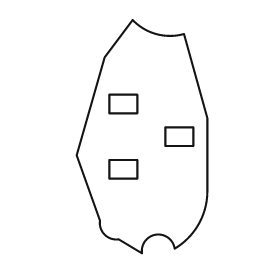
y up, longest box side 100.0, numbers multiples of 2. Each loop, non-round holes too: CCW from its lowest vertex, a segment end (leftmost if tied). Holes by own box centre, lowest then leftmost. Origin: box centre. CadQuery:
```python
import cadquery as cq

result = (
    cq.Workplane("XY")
    .moveTo(0.0, -50.0)
    .threePointArc((6.0, -42.0), (14.0, -48.0))
    .threePointArc((24.0, -38.0), (28.0, -24.0))
    .lineTo(28.0, 8.0)
    .lineTo(18.0, 44.0)
    .threePointArc((6.0, 44.0), (-4.0, 50.0))
    .lineTo(-16.0, 34.0)
    .lineTo(-28.0, -8.0)
    .lineTo(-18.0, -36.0)
    .threePointArc((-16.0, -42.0), (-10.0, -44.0))
    .close()
    .moveTo(-14.0, -18.0)
    .lineTo(-2.0, -18.0)
    .lineTo(-2.0, -10.0)
    .lineTo(-14.0, -10.0)
    .close()
    .moveTo(10.0, -4.0)
    .lineTo(22.0, -4.0)
    .lineTo(22.0, 4.0)
    .lineTo(10.0, 4.0)
    .close()
    .moveTo(-14.0, 10.0)
    .lineTo(-2.0, 10.0)
    .lineTo(-2.0, 18.0)
    .lineTo(-14.0, 18.0)
    .close()
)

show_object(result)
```